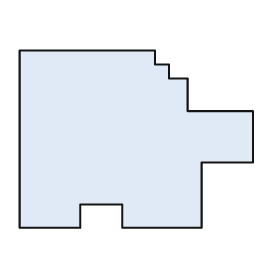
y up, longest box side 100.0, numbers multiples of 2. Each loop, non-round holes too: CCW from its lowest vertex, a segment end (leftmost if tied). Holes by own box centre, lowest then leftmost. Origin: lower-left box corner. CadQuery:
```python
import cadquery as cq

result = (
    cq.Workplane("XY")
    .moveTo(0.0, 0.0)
    .lineTo(26.0, 0.0)
    .lineTo(26.0, 10.0)
    .lineTo(44.0, 10.0)
    .lineTo(44.0, 0.0)
    .lineTo(78.0, 0.0)
    .lineTo(78.0, 28.0)
    .lineTo(100.0, 28.0)
    .lineTo(100.0, 50.0)
    .lineTo(72.0, 50.0)
    .lineTo(72.0, 64.0)
    .lineTo(64.0, 64.0)
    .lineTo(64.0, 70.0)
    .lineTo(58.0, 70.0)
    .lineTo(58.0, 76.0)
    .lineTo(0.0, 76.0)
    .close()
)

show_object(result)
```